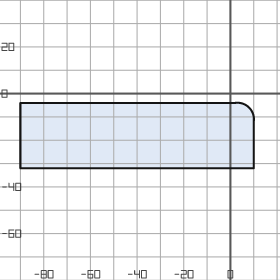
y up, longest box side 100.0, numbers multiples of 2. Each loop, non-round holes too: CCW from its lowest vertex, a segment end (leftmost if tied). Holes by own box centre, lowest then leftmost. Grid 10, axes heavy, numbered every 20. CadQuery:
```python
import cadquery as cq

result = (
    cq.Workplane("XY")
    .moveTo(-90.0, -32.0)
    .lineTo(10.0, -32.0)
    .lineTo(10.0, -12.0)
    .threePointArc((8.0, -6.0), (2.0, -4.0))
    .lineTo(-90.0, -4.0)
    .close()
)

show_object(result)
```